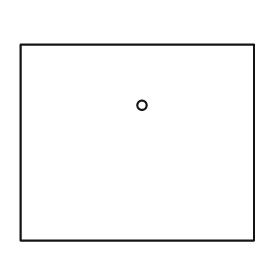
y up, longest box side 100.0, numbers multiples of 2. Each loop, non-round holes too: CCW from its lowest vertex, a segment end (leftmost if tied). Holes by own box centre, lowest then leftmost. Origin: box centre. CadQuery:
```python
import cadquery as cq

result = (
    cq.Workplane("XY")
    .moveTo(-50.0, -42.0)
    .lineTo(50.0, -42.0)
    .lineTo(50.0, 42.0)
    .lineTo(-50.0, 42.0)
    .close()
    .moveTo(2.0, 16.0)
    .circle(2.0)
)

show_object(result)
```